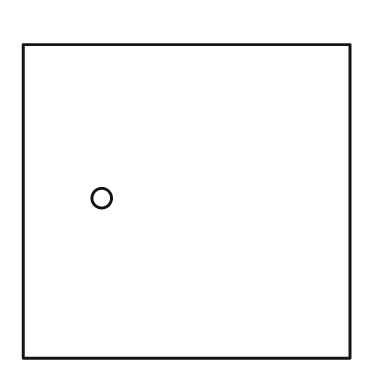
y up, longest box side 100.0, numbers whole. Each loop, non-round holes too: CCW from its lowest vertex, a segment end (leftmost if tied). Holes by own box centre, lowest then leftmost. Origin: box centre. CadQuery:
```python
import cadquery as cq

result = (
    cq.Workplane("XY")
    .moveTo(-50.0, -48.0)
    .lineTo(50.0, -48.0)
    .lineTo(50.0, 48.0)
    .lineTo(-50.0, 48.0)
    .close()
    .moveTo(-26.0, 1.0)
    .circle(3.0)
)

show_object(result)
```